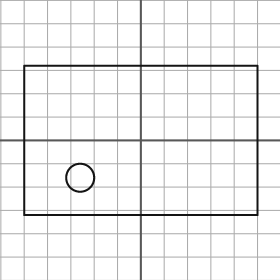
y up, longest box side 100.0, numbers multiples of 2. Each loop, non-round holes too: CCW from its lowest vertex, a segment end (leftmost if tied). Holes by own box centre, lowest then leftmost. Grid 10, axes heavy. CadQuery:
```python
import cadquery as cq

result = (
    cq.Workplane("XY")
    .moveTo(-50.0, -32.0)
    .lineTo(50.0, -32.0)
    .lineTo(50.0, 32.0)
    .lineTo(-50.0, 32.0)
    .close()
    .moveTo(-26.0, -16.0)
    .circle(6.0)
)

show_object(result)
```